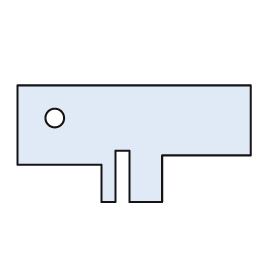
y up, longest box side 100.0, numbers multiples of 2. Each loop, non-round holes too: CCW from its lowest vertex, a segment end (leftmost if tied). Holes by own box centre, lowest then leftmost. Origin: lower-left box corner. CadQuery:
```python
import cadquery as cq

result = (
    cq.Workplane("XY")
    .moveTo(36.0, 0.0)
    .lineTo(42.0, 0.0)
    .lineTo(42.0, 22.0)
    .lineTo(48.0, 22.0)
    .lineTo(48.0, 0.0)
    .lineTo(62.0, 0.0)
    .lineTo(62.0, 20.0)
    .lineTo(100.0, 20.0)
    .lineTo(100.0, 50.0)
    .lineTo(0.0, 50.0)
    .lineTo(0.0, 16.0)
    .lineTo(36.0, 16.0)
    .close()
    .moveTo(16.0, 36.0)
    .circle(4.0)
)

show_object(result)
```